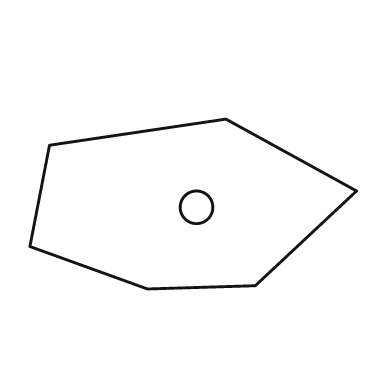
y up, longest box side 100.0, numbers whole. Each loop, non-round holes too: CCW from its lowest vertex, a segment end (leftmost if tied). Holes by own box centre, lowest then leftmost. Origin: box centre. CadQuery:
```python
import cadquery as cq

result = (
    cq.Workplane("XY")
    .moveTo(-14.0, -26.0)
    .lineTo(19.0, -25.0)
    .lineTo(50.0, 4.0)
    .lineTo(10.0, 26.0)
    .lineTo(-44.0, 18.0)
    .lineTo(-50.0, -13.0)
    .close()
    .moveTo(1.0, -1.0)
    .circle(5.0)
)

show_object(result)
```